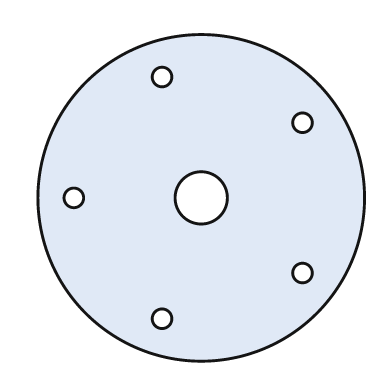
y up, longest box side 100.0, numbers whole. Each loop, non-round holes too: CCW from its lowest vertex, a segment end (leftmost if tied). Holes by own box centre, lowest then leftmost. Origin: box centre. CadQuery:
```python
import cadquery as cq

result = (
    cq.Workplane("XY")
    .moveTo(0.0, 0.0)
    .circle(50.0)
    .moveTo(-12.0, -37.0)
    .circle(3.0)
    .moveTo(31.0, -23.0)
    .circle(3.0)
    .moveTo(-39.0, 0.0)
    .circle(3.0)
    .moveTo(0.0, 0.0)
    .circle(8.0)
    .moveTo(31.0, 23.0)
    .circle(3.0)
    .moveTo(-12.0, 37.0)
    .circle(3.0)
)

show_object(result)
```